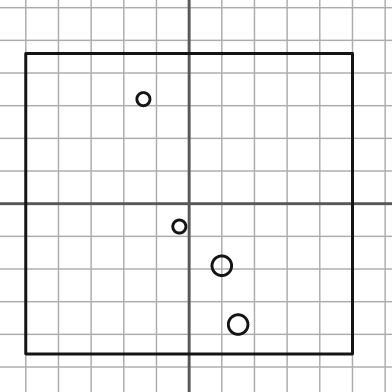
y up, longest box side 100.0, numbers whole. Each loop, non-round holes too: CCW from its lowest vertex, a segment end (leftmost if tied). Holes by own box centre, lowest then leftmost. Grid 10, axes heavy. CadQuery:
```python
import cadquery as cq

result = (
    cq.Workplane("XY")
    .moveTo(-50.0, -46.0)
    .lineTo(50.0, -46.0)
    .lineTo(50.0, 46.0)
    .lineTo(-50.0, 46.0)
    .close()
    .moveTo(15.0, -37.0)
    .circle(3.0)
    .moveTo(10.0, -19.0)
    .circle(3.0)
    .moveTo(-3.0, -7.0)
    .circle(2.0)
    .moveTo(-14.0, 32.0)
    .circle(2.0)
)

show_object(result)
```